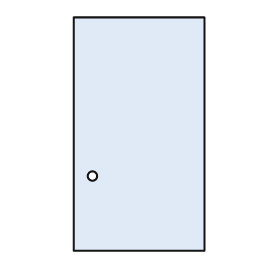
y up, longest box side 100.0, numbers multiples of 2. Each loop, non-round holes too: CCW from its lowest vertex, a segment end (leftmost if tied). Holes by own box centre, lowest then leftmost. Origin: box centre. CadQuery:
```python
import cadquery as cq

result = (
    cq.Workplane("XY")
    .moveTo(-28.0, -50.0)
    .lineTo(28.0, -50.0)
    .lineTo(28.0, 50.0)
    .lineTo(-28.0, 50.0)
    .close()
    .moveTo(-20.0, -18.0)
    .circle(2.0)
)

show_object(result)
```